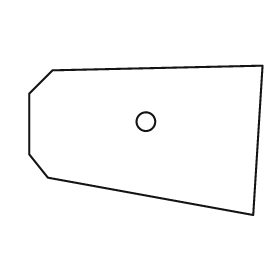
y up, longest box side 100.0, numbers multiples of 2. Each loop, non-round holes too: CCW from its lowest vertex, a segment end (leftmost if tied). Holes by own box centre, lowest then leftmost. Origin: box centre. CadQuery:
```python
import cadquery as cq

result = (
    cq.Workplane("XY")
    .moveTo(46.0, -32.0)
    .lineTo(50.0, 32.0)
    .lineTo(-40.0, 30.0)
    .lineTo(-50.0, 20.0)
    .lineTo(-50.0, -6.0)
    .lineTo(-42.0, -16.0)
    .close()
    .moveTo(0.0, 8.0)
    .circle(4.0)
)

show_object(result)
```